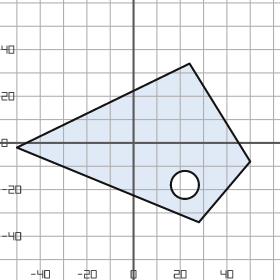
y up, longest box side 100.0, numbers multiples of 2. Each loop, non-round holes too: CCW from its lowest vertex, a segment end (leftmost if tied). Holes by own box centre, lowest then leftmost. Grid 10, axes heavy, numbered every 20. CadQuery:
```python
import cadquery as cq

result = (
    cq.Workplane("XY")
    .moveTo(28.0, -34.0)
    .lineTo(50.0, -8.0)
    .lineTo(24.0, 34.0)
    .lineTo(-50.0, -2.0)
    .close()
    .moveTo(22.0, -18.0)
    .circle(6.0)
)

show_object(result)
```